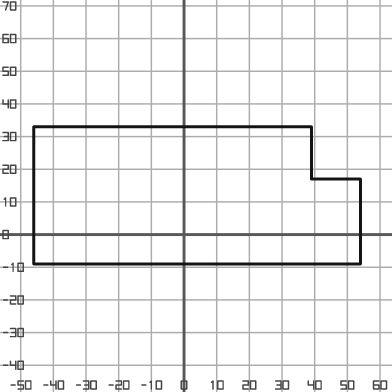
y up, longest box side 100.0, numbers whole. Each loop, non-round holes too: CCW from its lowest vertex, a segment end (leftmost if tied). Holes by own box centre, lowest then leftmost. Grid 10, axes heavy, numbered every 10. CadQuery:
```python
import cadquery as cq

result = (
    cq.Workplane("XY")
    .moveTo(-46.0, -9.0)
    .lineTo(54.0, -9.0)
    .lineTo(54.0, 17.0)
    .lineTo(39.0, 17.0)
    .lineTo(39.0, 33.0)
    .lineTo(-46.0, 33.0)
    .close()
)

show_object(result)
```